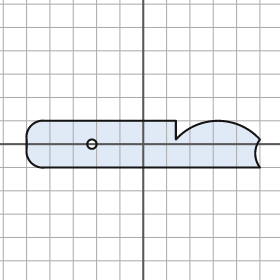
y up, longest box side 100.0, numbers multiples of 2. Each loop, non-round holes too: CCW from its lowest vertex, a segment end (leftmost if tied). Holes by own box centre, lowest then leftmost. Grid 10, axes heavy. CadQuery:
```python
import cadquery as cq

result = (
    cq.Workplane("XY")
    .moveTo(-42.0, -10.0)
    .lineTo(50.0, -10.0)
    .threePointArc((48.0, -4.0), (50.0, 2.0))
    .threePointArc((32.0, 10.0), (14.0, 2.0))
    .lineTo(14.0, 10.0)
    .lineTo(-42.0, 10.0)
    .threePointArc((-48.0, 8.0), (-50.0, 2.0))
    .lineTo(-50.0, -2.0)
    .threePointArc((-48.0, -8.0), (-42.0, -10.0))
    .close()
    .moveTo(-22.0, 0.0)
    .circle(2.0)
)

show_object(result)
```